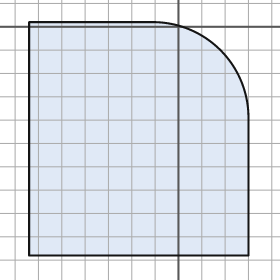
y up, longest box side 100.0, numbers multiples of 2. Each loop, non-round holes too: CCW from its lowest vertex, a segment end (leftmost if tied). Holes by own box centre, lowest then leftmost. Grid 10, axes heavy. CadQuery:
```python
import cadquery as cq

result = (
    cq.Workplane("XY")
    .moveTo(-64.0, -98.0)
    .lineTo(30.0, -98.0)
    .lineTo(30.0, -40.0)
    .threePointArc((18.0, -10.0), (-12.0, 2.0))
    .lineTo(-64.0, 2.0)
    .close()
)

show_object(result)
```